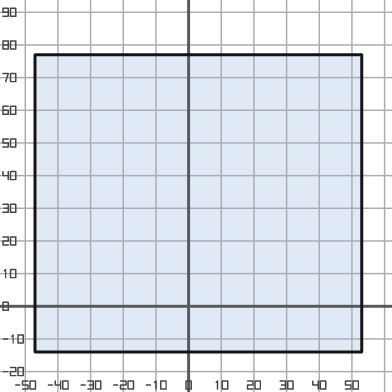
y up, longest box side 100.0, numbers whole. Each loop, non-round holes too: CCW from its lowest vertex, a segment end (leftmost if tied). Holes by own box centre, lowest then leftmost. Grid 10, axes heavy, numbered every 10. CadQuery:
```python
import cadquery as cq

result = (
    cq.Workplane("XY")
    .moveTo(-47.0, -14.0)
    .lineTo(53.0, -14.0)
    .lineTo(53.0, 77.0)
    .lineTo(-47.0, 77.0)
    .close()
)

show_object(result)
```